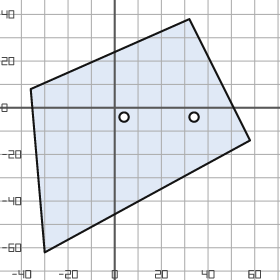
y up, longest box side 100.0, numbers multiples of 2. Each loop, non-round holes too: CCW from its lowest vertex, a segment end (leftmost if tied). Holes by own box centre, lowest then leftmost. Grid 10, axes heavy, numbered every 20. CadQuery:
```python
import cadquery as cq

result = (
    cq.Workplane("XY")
    .moveTo(-30.0, -62.0)
    .lineTo(58.0, -14.0)
    .lineTo(32.0, 38.0)
    .lineTo(-36.0, 8.0)
    .close()
    .moveTo(4.0, -4.0)
    .circle(2.0)
    .moveTo(34.0, -4.0)
    .circle(2.0)
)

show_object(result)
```